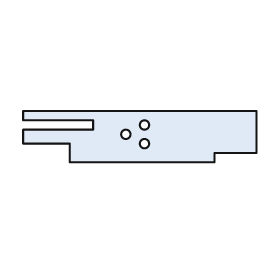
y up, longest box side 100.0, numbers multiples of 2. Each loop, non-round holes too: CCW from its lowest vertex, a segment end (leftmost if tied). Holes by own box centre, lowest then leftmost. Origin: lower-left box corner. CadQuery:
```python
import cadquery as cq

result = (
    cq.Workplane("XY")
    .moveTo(20.0, 0.0)
    .lineTo(82.0, 0.0)
    .lineTo(82.0, 4.0)
    .lineTo(100.0, 4.0)
    .lineTo(100.0, 22.0)
    .lineTo(0.0, 22.0)
    .lineTo(0.0, 18.0)
    .lineTo(30.0, 18.0)
    .lineTo(30.0, 14.0)
    .lineTo(0.0, 14.0)
    .lineTo(0.0, 8.0)
    .lineTo(20.0, 8.0)
    .close()
    .moveTo(52.0, 8.0)
    .circle(2.0)
    .moveTo(44.0, 12.0)
    .circle(2.0)
    .moveTo(52.0, 16.0)
    .circle(2.0)
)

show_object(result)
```